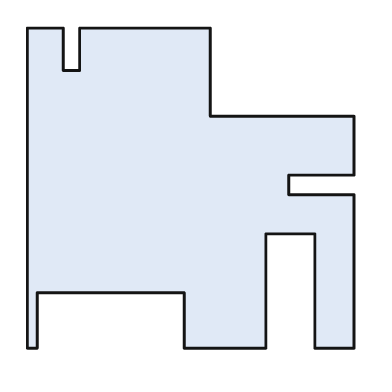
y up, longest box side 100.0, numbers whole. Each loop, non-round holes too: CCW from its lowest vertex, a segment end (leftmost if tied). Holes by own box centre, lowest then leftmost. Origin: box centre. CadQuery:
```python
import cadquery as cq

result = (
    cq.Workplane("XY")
    .moveTo(-50.0, -49.0)
    .lineTo(-47.0, -49.0)
    .lineTo(-47.0, -32.0)
    .lineTo(-2.0, -32.0)
    .lineTo(-2.0, -49.0)
    .lineTo(23.0, -49.0)
    .lineTo(23.0, -14.0)
    .lineTo(38.0, -14.0)
    .lineTo(38.0, -49.0)
    .lineTo(50.0, -49.0)
    .lineTo(50.0, -2.0)
    .lineTo(30.0, -2.0)
    .lineTo(30.0, 4.0)
    .lineTo(50.0, 4.0)
    .lineTo(50.0, 22.0)
    .lineTo(6.0, 22.0)
    .lineTo(6.0, 49.0)
    .lineTo(-34.0, 49.0)
    .lineTo(-34.0, 36.0)
    .lineTo(-39.0, 36.0)
    .lineTo(-39.0, 49.0)
    .lineTo(-50.0, 49.0)
    .close()
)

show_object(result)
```